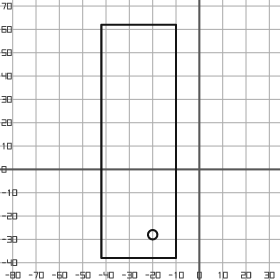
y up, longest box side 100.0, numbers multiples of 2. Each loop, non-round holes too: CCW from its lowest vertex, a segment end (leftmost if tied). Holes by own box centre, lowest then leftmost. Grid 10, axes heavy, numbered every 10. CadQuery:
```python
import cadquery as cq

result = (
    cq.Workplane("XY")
    .moveTo(-42.0, -38.0)
    .lineTo(-10.0, -38.0)
    .lineTo(-10.0, 62.0)
    .lineTo(-42.0, 62.0)
    .close()
    .moveTo(-20.0, -28.0)
    .circle(2.0)
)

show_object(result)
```